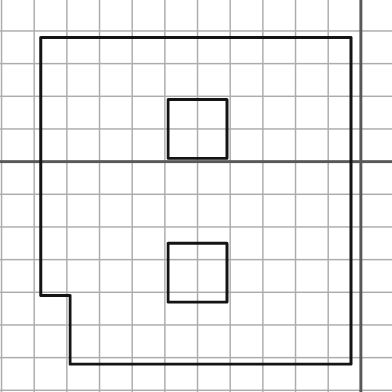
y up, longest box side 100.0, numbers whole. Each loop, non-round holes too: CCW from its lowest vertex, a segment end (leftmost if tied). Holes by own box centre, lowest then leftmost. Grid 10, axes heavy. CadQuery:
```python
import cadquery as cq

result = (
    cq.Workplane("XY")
    .moveTo(-89.0, -62.0)
    .lineTo(-3.0, -62.0)
    .lineTo(-3.0, 38.0)
    .lineTo(-98.0, 38.0)
    .lineTo(-98.0, -41.0)
    .lineTo(-89.0, -41.0)
    .close()
    .moveTo(-59.0, -43.0)
    .lineTo(-41.0, -43.0)
    .lineTo(-41.0, -25.0)
    .lineTo(-59.0, -25.0)
    .close()
    .moveTo(-59.0, 1.0)
    .lineTo(-41.0, 1.0)
    .lineTo(-41.0, 19.0)
    .lineTo(-59.0, 19.0)
    .close()
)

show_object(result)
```